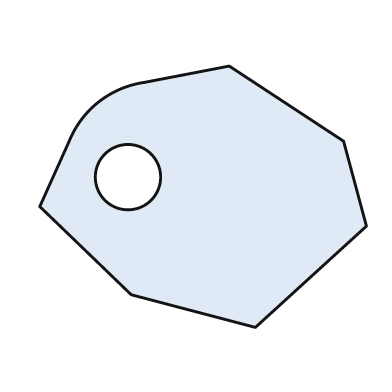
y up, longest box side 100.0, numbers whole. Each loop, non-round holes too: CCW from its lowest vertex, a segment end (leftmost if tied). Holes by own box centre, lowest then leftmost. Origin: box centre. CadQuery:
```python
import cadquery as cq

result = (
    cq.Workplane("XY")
    .moveTo(16.0, -40.0)
    .lineTo(50.0, -9.0)
    .lineTo(43.0, 17.0)
    .lineTo(8.0, 40.0)
    .lineTo(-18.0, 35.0)
    .threePointArc((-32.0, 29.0), (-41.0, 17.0))
    .lineTo(-50.0, -3.0)
    .lineTo(-22.0, -30.0)
    .close()
    .moveTo(-23.0, 6.0)
    .circle(10.0)
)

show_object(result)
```